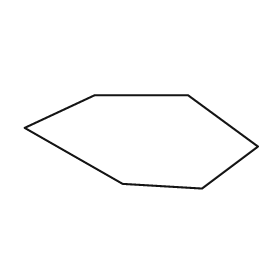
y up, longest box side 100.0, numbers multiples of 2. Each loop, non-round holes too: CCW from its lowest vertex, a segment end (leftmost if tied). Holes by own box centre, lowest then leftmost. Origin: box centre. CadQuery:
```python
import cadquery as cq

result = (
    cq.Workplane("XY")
    .moveTo(26.0, -20.0)
    .lineTo(50.0, -2.0)
    .lineTo(20.0, 20.0)
    .lineTo(-20.0, 20.0)
    .lineTo(-50.0, 6.0)
    .lineTo(-8.0, -18.0)
    .close()
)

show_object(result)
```